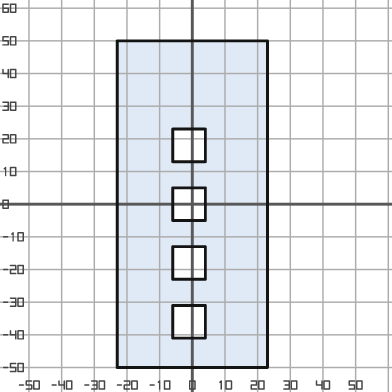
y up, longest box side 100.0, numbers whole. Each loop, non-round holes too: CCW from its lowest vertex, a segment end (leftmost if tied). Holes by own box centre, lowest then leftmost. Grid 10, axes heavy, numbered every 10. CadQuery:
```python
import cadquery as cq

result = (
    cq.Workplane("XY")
    .moveTo(-23.0, -50.0)
    .lineTo(23.0, -50.0)
    .lineTo(23.0, 50.0)
    .lineTo(-23.0, 50.0)
    .close()
    .moveTo(-6.0, -41.0)
    .lineTo(4.0, -41.0)
    .lineTo(4.0, -31.0)
    .lineTo(-6.0, -31.0)
    .close()
    .moveTo(-6.0, -23.0)
    .lineTo(4.0, -23.0)
    .lineTo(4.0, -13.0)
    .lineTo(-6.0, -13.0)
    .close()
    .moveTo(-6.0, -5.0)
    .lineTo(4.0, -5.0)
    .lineTo(4.0, 5.0)
    .lineTo(-6.0, 5.0)
    .close()
    .moveTo(-6.0, 13.0)
    .lineTo(4.0, 13.0)
    .lineTo(4.0, 23.0)
    .lineTo(-6.0, 23.0)
    .close()
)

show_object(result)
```